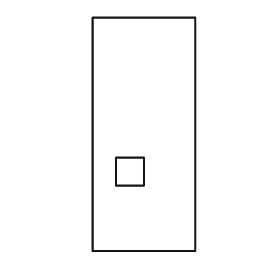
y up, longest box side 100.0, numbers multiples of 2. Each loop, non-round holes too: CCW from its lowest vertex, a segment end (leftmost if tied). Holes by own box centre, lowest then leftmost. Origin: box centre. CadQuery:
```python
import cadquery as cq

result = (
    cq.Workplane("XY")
    .moveTo(-22.0, -50.0)
    .lineTo(22.0, -50.0)
    .lineTo(22.0, 50.0)
    .lineTo(-22.0, 50.0)
    .close()
    .moveTo(-12.0, -22.0)
    .lineTo(0.0, -22.0)
    .lineTo(0.0, -10.0)
    .lineTo(-12.0, -10.0)
    .close()
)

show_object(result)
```